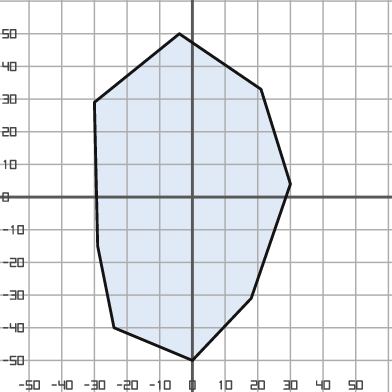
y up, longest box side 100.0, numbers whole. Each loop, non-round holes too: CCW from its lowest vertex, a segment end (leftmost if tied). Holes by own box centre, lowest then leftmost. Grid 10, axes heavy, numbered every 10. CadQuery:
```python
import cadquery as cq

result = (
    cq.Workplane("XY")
    .moveTo(0.0, -50.0)
    .lineTo(18.0, -31.0)
    .lineTo(30.0, 4.0)
    .lineTo(21.0, 33.0)
    .lineTo(-4.0, 50.0)
    .lineTo(-30.0, 29.0)
    .lineTo(-29.0, -15.0)
    .lineTo(-24.0, -40.0)
    .close()
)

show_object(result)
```